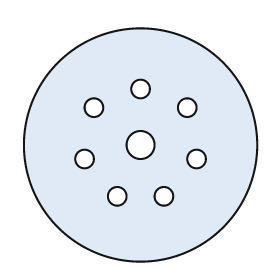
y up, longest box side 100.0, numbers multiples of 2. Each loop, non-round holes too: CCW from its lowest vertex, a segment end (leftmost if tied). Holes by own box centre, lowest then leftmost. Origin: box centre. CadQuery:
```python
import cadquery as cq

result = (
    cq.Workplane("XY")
    .moveTo(0.0, 0.0)
    .circle(50.0)
    .moveTo(-10.0, -22.0)
    .circle(4.0)
    .moveTo(10.0, -22.0)
    .circle(4.0)
    .moveTo(-24.0, -6.0)
    .circle(4.0)
    .moveTo(24.0, -6.0)
    .circle(4.0)
    .moveTo(0.0, 0.0)
    .circle(6.0)
    .moveTo(-20.0, 16.0)
    .circle(4.0)
    .moveTo(20.0, 16.0)
    .circle(4.0)
    .moveTo(0.0, 24.0)
    .circle(4.0)
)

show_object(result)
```